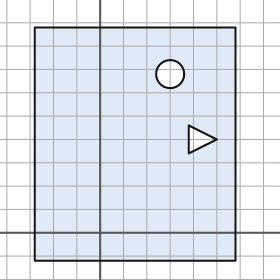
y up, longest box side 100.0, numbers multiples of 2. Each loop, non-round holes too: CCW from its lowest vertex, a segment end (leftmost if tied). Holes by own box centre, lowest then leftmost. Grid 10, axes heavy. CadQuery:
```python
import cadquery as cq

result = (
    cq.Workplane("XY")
    .moveTo(-28.0, -12.0)
    .lineTo(58.0, -12.0)
    .lineTo(58.0, 88.0)
    .lineTo(-28.0, 88.0)
    .close()
    .moveTo(38.0, 34.0)
    .lineTo(50.0, 40.0)
    .lineTo(38.0, 46.0)
    .close()
    .moveTo(30.0, 68.0)
    .circle(6.0)
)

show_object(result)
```